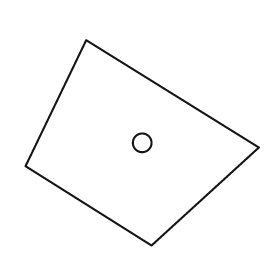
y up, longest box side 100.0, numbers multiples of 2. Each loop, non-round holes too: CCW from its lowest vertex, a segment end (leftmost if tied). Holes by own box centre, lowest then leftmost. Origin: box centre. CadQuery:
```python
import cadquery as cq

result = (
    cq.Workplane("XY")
    .moveTo(4.0, -44.0)
    .lineTo(50.0, -2.0)
    .lineTo(-24.0, 44.0)
    .lineTo(-50.0, -10.0)
    .close()
    .moveTo(0.0, 0.0)
    .circle(4.0)
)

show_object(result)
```